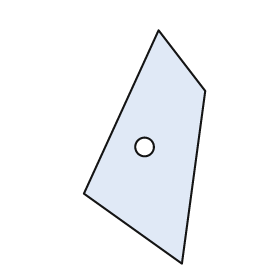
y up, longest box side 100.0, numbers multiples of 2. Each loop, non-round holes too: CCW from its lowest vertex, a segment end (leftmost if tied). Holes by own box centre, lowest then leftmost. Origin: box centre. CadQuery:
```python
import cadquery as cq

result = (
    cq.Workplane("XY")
    .moveTo(16.0, -50.0)
    .lineTo(26.0, 24.0)
    .lineTo(6.0, 50.0)
    .lineTo(-26.0, -20.0)
    .close()
    .moveTo(0.0, 0.0)
    .circle(4.0)
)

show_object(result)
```